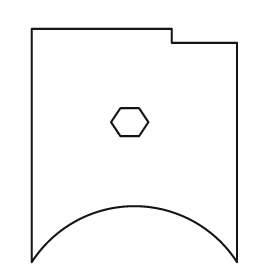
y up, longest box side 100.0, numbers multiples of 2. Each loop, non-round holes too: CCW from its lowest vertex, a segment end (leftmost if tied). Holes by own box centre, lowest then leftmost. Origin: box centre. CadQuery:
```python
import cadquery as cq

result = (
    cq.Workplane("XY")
    .moveTo(-44.0, -50.0)
    .threePointArc((0.0, -26.0), (44.0, -50.0))
    .lineTo(44.0, 44.0)
    .lineTo(16.0, 44.0)
    .lineTo(16.0, 50.0)
    .lineTo(-44.0, 50.0)
    .close()
    .moveTo(-6.0, 4.0)
    .lineTo(2.0, 4.0)
    .lineTo(6.0, 10.0)
    .lineTo(2.0, 16.0)
    .lineTo(-6.0, 16.0)
    .lineTo(-10.0, 10.0)
    .close()
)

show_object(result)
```